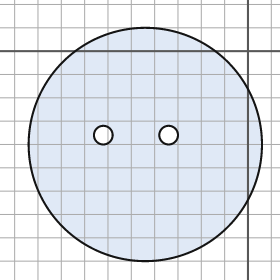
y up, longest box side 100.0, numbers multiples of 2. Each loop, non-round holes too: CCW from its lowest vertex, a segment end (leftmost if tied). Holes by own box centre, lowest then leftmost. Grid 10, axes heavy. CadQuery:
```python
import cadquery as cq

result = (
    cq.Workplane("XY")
    .moveTo(-44.0, -40.0)
    .circle(50.0)
    .moveTo(-62.0, -36.0)
    .circle(4.0)
    .moveTo(-34.0, -36.0)
    .circle(4.0)
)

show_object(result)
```